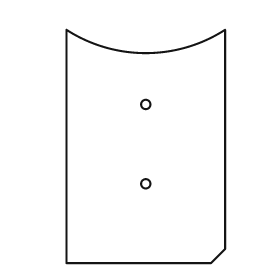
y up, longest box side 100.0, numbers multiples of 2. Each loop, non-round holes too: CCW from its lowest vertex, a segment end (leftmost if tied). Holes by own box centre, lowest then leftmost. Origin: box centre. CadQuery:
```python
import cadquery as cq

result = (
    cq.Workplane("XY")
    .moveTo(-34.0, -50.0)
    .lineTo(28.0, -50.0)
    .lineTo(34.0, -44.0)
    .lineTo(34.0, 50.0)
    .threePointArc((0.0, 40.0), (-34.0, 50.0))
    .close()
    .moveTo(0.0, -16.0)
    .circle(2.0)
    .moveTo(0.0, 18.0)
    .circle(2.0)
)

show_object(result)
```